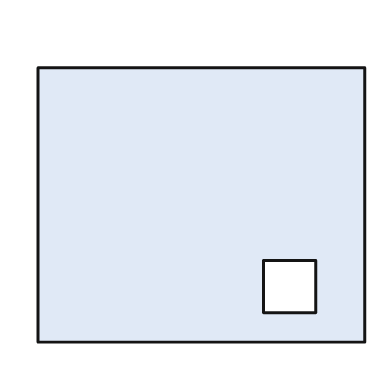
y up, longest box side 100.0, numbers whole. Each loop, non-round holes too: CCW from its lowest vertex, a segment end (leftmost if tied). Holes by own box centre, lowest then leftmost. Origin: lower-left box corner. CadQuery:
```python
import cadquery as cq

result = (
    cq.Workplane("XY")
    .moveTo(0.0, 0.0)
    .lineTo(100.0, 0.0)
    .lineTo(100.0, 84.0)
    .lineTo(0.0, 84.0)
    .close()
    .moveTo(69.0, 9.0)
    .lineTo(85.0, 9.0)
    .lineTo(85.0, 25.0)
    .lineTo(69.0, 25.0)
    .close()
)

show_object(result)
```